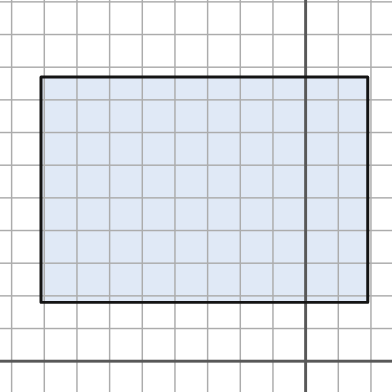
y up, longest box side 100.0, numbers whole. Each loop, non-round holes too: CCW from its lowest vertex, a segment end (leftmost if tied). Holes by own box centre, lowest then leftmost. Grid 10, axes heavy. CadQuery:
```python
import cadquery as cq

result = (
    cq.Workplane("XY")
    .moveTo(-81.0, 18.0)
    .lineTo(19.0, 18.0)
    .lineTo(19.0, 87.0)
    .lineTo(-81.0, 87.0)
    .close()
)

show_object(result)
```